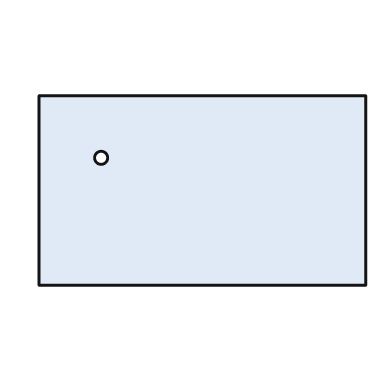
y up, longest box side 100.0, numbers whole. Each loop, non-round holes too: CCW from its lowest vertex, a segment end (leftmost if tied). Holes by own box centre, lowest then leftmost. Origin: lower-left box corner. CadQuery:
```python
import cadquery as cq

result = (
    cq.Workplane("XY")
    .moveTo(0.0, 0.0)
    .lineTo(100.0, 0.0)
    .lineTo(100.0, 58.0)
    .lineTo(0.0, 58.0)
    .close()
    .moveTo(19.0, 39.0)
    .circle(2.0)
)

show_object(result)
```